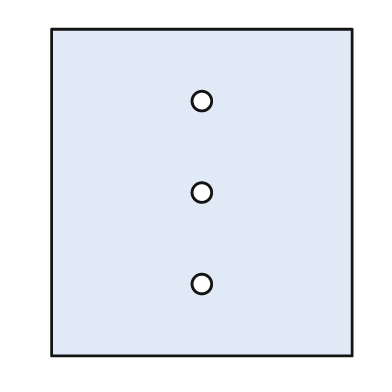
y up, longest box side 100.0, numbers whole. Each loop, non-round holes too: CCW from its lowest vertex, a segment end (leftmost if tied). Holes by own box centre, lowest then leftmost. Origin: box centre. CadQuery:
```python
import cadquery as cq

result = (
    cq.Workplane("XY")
    .moveTo(-46.0, -50.0)
    .lineTo(46.0, -50.0)
    .lineTo(46.0, 50.0)
    .lineTo(-46.0, 50.0)
    .close()
    .moveTo(0.0, -28.0)
    .circle(3.0)
    .moveTo(0.0, 0.0)
    .circle(3.0)
    .moveTo(0.0, 28.0)
    .circle(3.0)
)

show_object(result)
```